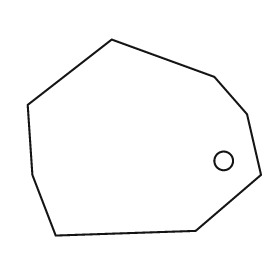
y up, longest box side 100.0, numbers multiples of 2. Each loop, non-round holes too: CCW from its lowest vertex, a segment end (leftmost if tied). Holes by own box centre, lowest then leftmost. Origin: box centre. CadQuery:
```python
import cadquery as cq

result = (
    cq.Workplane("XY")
    .moveTo(-38.0, -42.0)
    .lineTo(22.0, -40.0)
    .lineTo(50.0, -16.0)
    .lineTo(44.0, 10.0)
    .lineTo(30.0, 26.0)
    .lineTo(-14.0, 42.0)
    .lineTo(-50.0, 14.0)
    .lineTo(-48.0, -16.0)
    .close()
    .moveTo(34.0, -10.0)
    .circle(4.0)
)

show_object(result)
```